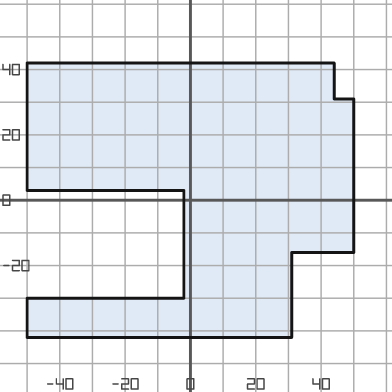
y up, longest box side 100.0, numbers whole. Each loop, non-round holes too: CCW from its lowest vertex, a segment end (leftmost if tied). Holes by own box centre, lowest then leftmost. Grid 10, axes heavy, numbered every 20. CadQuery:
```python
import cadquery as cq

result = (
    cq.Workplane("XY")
    .moveTo(-50.0, -42.0)
    .lineTo(31.0, -42.0)
    .lineTo(31.0, -16.0)
    .lineTo(50.0, -16.0)
    .lineTo(50.0, 31.0)
    .lineTo(44.0, 31.0)
    .lineTo(44.0, 42.0)
    .lineTo(-50.0, 42.0)
    .lineTo(-50.0, 3.0)
    .lineTo(-2.0, 3.0)
    .lineTo(-2.0, -30.0)
    .lineTo(-50.0, -30.0)
    .close()
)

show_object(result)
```